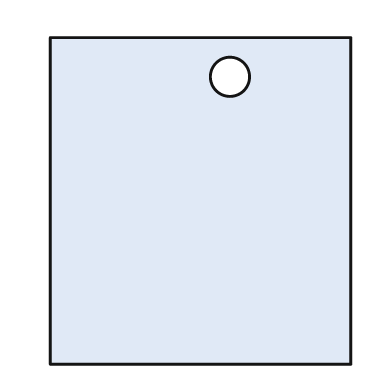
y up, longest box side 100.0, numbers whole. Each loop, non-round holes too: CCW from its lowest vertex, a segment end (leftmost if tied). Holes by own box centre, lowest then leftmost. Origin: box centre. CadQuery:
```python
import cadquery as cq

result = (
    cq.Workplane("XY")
    .moveTo(-46.0, -50.0)
    .lineTo(46.0, -50.0)
    .lineTo(46.0, 50.0)
    .lineTo(-46.0, 50.0)
    .close()
    .moveTo(9.0, 38.0)
    .circle(6.0)
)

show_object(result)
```